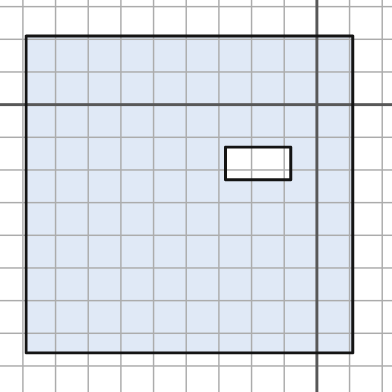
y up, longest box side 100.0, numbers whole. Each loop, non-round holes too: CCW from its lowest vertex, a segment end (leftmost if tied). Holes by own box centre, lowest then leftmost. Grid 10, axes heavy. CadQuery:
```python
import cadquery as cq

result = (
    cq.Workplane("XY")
    .moveTo(-89.0, -76.0)
    .lineTo(11.0, -76.0)
    .lineTo(11.0, 21.0)
    .lineTo(-89.0, 21.0)
    .close()
    .moveTo(-28.0, -23.0)
    .lineTo(-8.0, -23.0)
    .lineTo(-8.0, -13.0)
    .lineTo(-28.0, -13.0)
    .close()
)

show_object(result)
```